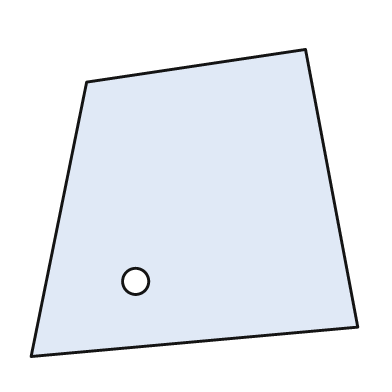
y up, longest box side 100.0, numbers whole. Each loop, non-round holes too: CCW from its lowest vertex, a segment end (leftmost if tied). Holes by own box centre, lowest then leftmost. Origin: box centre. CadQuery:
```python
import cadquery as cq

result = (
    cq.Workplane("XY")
    .moveTo(-50.0, -47.0)
    .lineTo(50.0, -38.0)
    .lineTo(34.0, 47.0)
    .lineTo(-33.0, 37.0)
    .close()
    .moveTo(-18.0, -24.0)
    .circle(4.0)
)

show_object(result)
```